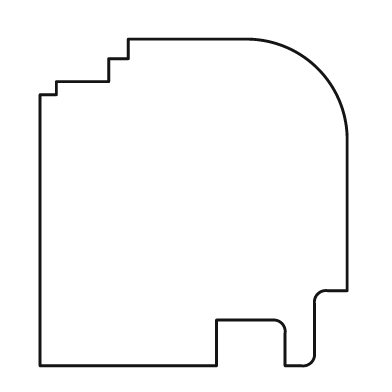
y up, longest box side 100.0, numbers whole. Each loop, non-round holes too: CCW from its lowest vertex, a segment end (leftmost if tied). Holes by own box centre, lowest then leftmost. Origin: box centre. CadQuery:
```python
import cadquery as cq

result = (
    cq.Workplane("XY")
    .moveTo(-47.0, -50.0)
    .lineTo(7.0, -50.0)
    .lineTo(7.0, -36.0)
    .lineTo(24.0, -36.0)
    .threePointArc((27.0, -37.0), (28.0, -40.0))
    .lineTo(28.0, -50.0)
    .lineTo(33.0, -50.0)
    .threePointArc((36.0, -49.0), (37.0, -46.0))
    .lineTo(37.0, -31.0)
    .threePointArc((38.0, -28.0), (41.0, -27.0))
    .lineTo(47.0, -27.0)
    .lineTo(47.0, 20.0)
    .threePointArc((38.0, 41.0), (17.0, 50.0))
    .lineTo(-20.0, 50.0)
    .lineTo(-20.0, 44.0)
    .lineTo(-26.0, 44.0)
    .lineTo(-26.0, 37.0)
    .lineTo(-42.0, 37.0)
    .lineTo(-42.0, 33.0)
    .lineTo(-47.0, 33.0)
    .close()
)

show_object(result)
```